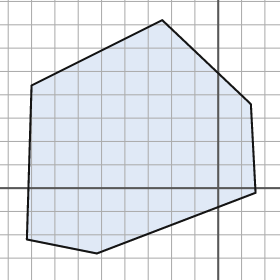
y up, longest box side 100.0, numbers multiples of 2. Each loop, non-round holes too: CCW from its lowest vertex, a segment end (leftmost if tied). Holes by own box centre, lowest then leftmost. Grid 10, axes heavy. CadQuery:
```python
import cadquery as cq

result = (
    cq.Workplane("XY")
    .moveTo(-52.0, -28.0)
    .lineTo(16.0, -2.0)
    .lineTo(14.0, 36.0)
    .lineTo(-24.0, 72.0)
    .lineTo(-80.0, 44.0)
    .lineTo(-82.0, -22.0)
    .close()
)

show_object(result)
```